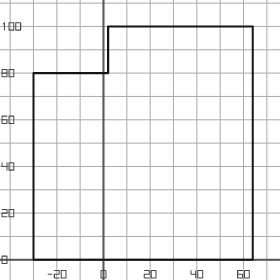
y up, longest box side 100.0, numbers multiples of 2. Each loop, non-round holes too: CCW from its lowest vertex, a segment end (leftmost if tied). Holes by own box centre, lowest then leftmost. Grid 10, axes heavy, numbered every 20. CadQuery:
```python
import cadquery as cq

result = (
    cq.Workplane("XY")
    .moveTo(-30.0, 0.0)
    .lineTo(64.0, 0.0)
    .lineTo(64.0, 100.0)
    .lineTo(2.0, 100.0)
    .lineTo(2.0, 80.0)
    .lineTo(-30.0, 80.0)
    .close()
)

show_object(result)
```